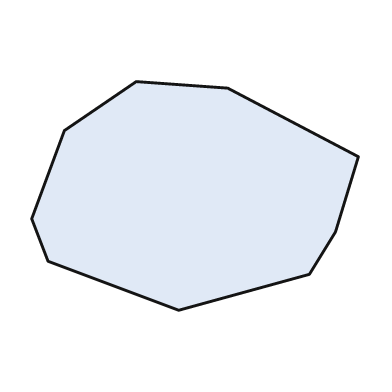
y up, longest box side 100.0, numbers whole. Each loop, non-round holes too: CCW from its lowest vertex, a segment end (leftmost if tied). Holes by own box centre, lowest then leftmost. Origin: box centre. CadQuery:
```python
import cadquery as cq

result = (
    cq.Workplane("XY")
    .moveTo(-5.0, -35.0)
    .lineTo(35.0, -24.0)
    .lineTo(43.0, -11.0)
    .lineTo(50.0, 12.0)
    .lineTo(10.0, 33.0)
    .lineTo(-18.0, 35.0)
    .lineTo(-40.0, 20.0)
    .lineTo(-50.0, -7.0)
    .lineTo(-45.0, -20.0)
    .close()
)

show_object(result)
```